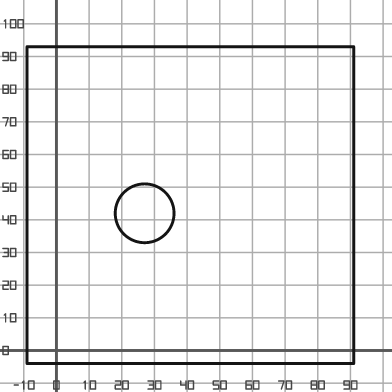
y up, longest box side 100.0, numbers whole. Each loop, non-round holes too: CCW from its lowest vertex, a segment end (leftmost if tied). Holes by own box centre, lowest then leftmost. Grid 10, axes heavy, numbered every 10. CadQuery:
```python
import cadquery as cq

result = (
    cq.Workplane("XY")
    .moveTo(-9.0, -4.0)
    .lineTo(91.0, -4.0)
    .lineTo(91.0, 93.0)
    .lineTo(-9.0, 93.0)
    .close()
    .moveTo(27.0, 42.0)
    .circle(9.0)
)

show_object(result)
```